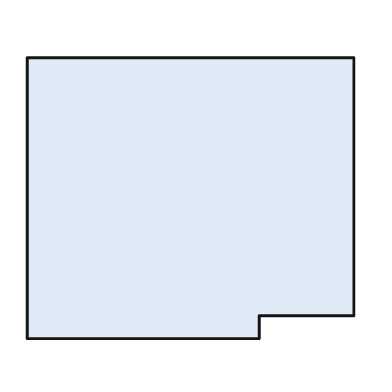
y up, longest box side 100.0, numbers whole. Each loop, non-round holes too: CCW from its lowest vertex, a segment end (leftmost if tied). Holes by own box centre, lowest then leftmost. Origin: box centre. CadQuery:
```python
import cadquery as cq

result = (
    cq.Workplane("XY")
    .moveTo(-50.0, -43.0)
    .lineTo(21.0, -43.0)
    .lineTo(21.0, -36.0)
    .lineTo(50.0, -36.0)
    .lineTo(50.0, 43.0)
    .lineTo(-50.0, 43.0)
    .close()
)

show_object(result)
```